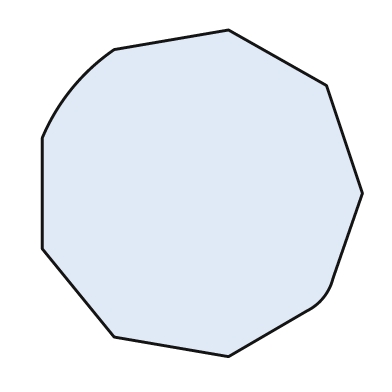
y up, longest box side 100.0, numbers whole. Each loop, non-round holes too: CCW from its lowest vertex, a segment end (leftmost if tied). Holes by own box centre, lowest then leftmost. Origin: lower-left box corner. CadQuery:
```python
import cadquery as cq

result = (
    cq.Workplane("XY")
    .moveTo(57.0, 0.0)
    .lineTo(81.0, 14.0)
    .threePointArc((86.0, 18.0), (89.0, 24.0))
    .lineTo(98.0, 50.0)
    .lineTo(87.0, 83.0)
    .lineTo(57.0, 100.0)
    .lineTo(22.0, 94.0)
    .threePointArc((9.0, 82.0), (0.0, 67.0))
    .lineTo(0.0, 33.0)
    .lineTo(22.0, 6.0)
    .close()
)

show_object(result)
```